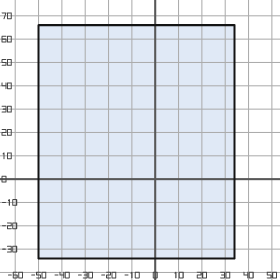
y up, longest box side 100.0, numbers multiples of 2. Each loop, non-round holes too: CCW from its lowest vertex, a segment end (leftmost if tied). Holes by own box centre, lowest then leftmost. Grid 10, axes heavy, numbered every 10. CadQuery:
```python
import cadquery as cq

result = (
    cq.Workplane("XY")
    .moveTo(-50.0, -34.0)
    .lineTo(34.0, -34.0)
    .lineTo(34.0, 66.0)
    .lineTo(-50.0, 66.0)
    .close()
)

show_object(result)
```